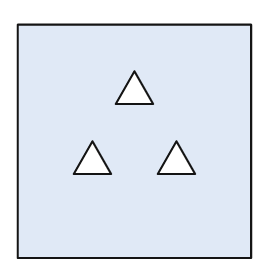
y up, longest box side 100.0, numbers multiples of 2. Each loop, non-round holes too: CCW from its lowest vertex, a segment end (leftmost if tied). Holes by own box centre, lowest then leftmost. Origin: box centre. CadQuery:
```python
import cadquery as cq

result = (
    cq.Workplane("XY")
    .moveTo(-50.0, -50.0)
    .lineTo(50.0, -50.0)
    .lineTo(50.0, 50.0)
    .lineTo(-50.0, 50.0)
    .close()
    .moveTo(-26.0, -14.0)
    .lineTo(-10.0, -14.0)
    .lineTo(-18.0, 0.0)
    .close()
    .moveTo(10.0, -14.0)
    .lineTo(26.0, -14.0)
    .lineTo(18.0, 0.0)
    .close()
    .moveTo(-8.0, 16.0)
    .lineTo(8.0, 16.0)
    .lineTo(0.0, 30.0)
    .close()
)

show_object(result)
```